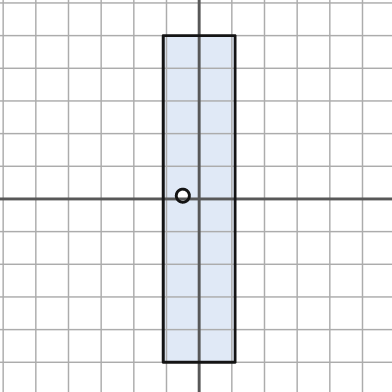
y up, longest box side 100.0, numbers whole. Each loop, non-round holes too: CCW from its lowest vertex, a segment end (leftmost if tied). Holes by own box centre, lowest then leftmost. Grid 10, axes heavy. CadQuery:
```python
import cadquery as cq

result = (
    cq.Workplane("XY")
    .moveTo(-11.0, -50.0)
    .lineTo(11.0, -50.0)
    .lineTo(11.0, 50.0)
    .lineTo(-11.0, 50.0)
    .close()
    .moveTo(-5.0, 1.0)
    .circle(2.0)
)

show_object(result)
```